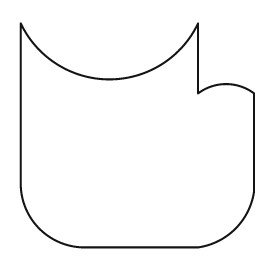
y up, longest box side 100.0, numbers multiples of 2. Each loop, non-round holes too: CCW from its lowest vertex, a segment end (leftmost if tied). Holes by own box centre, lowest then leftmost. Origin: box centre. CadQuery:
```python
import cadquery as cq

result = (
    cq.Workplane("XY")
    .moveTo(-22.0, -48.0)
    .lineTo(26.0, -48.0)
    .threePointArc((42.0, -40.0), (50.0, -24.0))
    .lineTo(50.0, 18.0)
    .threePointArc((38.0, 22.0), (26.0, 18.0))
    .lineTo(26.0, 48.0)
    .threePointArc((-12.0, 24.0), (-50.0, 48.0))
    .lineTo(-50.0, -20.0)
    .threePointArc((-42.0, -40.0), (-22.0, -48.0))
    .close()
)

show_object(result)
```